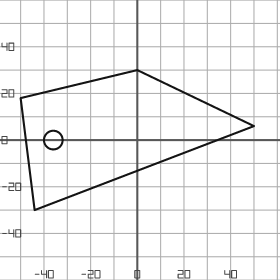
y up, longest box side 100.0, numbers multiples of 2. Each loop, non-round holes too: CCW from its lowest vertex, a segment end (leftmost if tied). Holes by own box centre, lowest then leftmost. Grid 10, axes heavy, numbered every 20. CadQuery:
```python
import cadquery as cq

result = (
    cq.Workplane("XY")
    .moveTo(-44.0, -30.0)
    .lineTo(50.0, 6.0)
    .lineTo(0.0, 30.0)
    .lineTo(-50.0, 18.0)
    .close()
    .moveTo(-36.0, 0.0)
    .circle(4.0)
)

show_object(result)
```